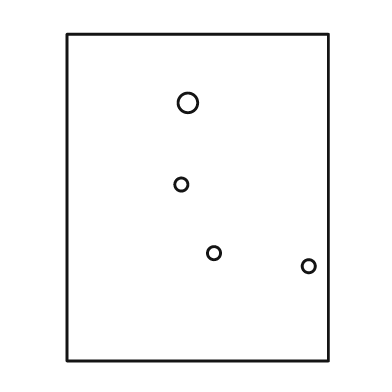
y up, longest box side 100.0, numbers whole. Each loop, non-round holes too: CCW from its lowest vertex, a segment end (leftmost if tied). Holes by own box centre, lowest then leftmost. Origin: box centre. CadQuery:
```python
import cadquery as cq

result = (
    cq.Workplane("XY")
    .moveTo(-40.0, -50.0)
    .lineTo(40.0, -50.0)
    .lineTo(40.0, 50.0)
    .lineTo(-40.0, 50.0)
    .close()
    .moveTo(34.0, -21.0)
    .circle(2.0)
    .moveTo(5.0, -17.0)
    .circle(2.0)
    .moveTo(-5.0, 4.0)
    .circle(2.0)
    .moveTo(-3.0, 29.0)
    .circle(3.0)
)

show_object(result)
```